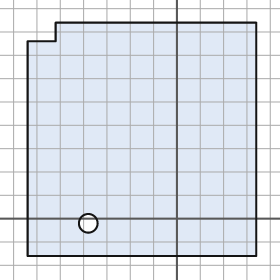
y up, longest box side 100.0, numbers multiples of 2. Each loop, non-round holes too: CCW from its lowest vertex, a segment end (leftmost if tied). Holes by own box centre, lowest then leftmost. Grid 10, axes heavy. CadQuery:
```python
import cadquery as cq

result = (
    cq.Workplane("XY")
    .moveTo(-64.0, -16.0)
    .lineTo(34.0, -16.0)
    .lineTo(34.0, 84.0)
    .lineTo(-52.0, 84.0)
    .lineTo(-52.0, 76.0)
    .lineTo(-64.0, 76.0)
    .close()
    .moveTo(-38.0, -2.0)
    .circle(4.0)
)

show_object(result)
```